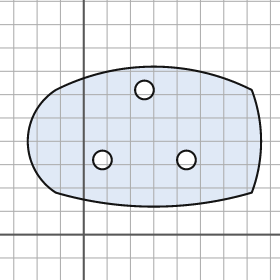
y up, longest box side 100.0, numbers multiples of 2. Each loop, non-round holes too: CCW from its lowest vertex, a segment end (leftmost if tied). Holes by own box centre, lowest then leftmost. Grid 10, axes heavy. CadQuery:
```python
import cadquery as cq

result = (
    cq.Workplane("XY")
    .moveTo(-12.0, 18.0)
    .threePointArc((30.0, 12.0), (72.0, 18.0))
    .threePointArc((76.0, 40.0), (72.0, 62.0))
    .threePointArc((30.0, 72.0), (-12.0, 62.0))
    .threePointArc((-24.0, 40.0), (-12.0, 18.0))
    .close()
    .moveTo(8.0, 32.0)
    .circle(4.0)
    .moveTo(44.0, 32.0)
    .circle(4.0)
    .moveTo(26.0, 62.0)
    .circle(4.0)
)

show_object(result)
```